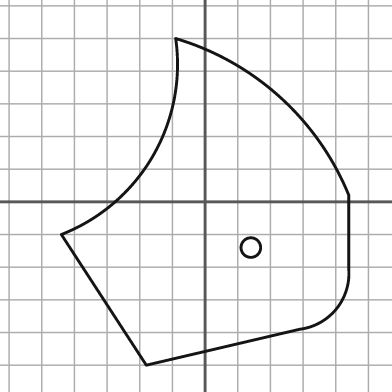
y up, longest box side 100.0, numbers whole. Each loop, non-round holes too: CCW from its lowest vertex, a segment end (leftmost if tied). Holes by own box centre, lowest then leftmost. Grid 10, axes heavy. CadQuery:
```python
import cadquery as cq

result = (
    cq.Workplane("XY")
    .moveTo(-18.0, -50.0)
    .lineTo(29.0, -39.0)
    .threePointArc((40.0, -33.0), (44.0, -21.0))
    .lineTo(44.0, 2.0)
    .threePointArc((23.0, 32.0), (-9.0, 50.0))
    .threePointArc((-16.0, 14.0), (-44.0, -10.0))
    .close()
    .moveTo(14.0, -14.0)
    .circle(3.0)
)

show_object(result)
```